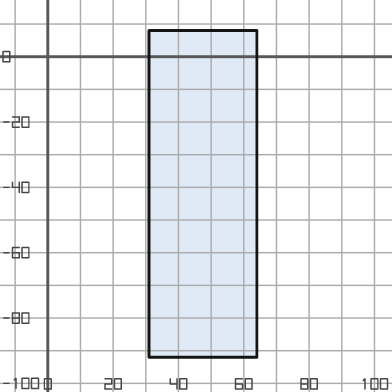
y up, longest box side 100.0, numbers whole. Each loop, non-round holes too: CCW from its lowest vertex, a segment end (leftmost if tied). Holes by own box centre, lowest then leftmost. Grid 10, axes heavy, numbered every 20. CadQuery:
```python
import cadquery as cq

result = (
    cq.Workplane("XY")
    .moveTo(31.0, -92.0)
    .lineTo(64.0, -92.0)
    .lineTo(64.0, 8.0)
    .lineTo(31.0, 8.0)
    .close()
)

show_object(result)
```